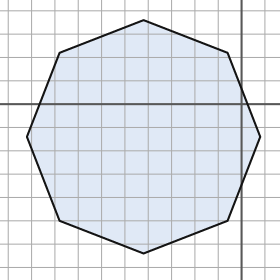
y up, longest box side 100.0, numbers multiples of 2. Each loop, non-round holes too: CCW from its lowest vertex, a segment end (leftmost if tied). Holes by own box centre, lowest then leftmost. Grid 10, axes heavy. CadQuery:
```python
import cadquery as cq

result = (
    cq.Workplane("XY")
    .moveTo(-42.0, -64.0)
    .lineTo(-6.0, -50.0)
    .lineTo(8.0, -14.0)
    .lineTo(-6.0, 22.0)
    .lineTo(-42.0, 36.0)
    .lineTo(-78.0, 22.0)
    .lineTo(-92.0, -14.0)
    .lineTo(-78.0, -50.0)
    .close()
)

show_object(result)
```